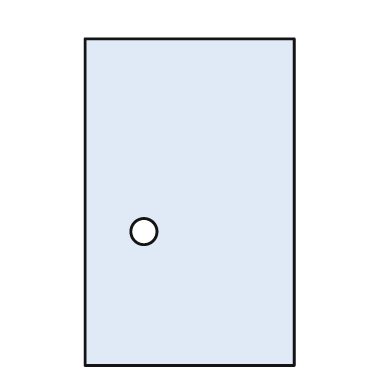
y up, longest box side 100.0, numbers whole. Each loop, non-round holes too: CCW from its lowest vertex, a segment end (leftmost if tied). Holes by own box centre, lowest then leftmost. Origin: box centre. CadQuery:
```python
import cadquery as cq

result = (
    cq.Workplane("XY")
    .moveTo(-32.0, -50.0)
    .lineTo(32.0, -50.0)
    .lineTo(32.0, 50.0)
    .lineTo(-32.0, 50.0)
    .close()
    .moveTo(-14.0, -9.0)
    .circle(4.0)
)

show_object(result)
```